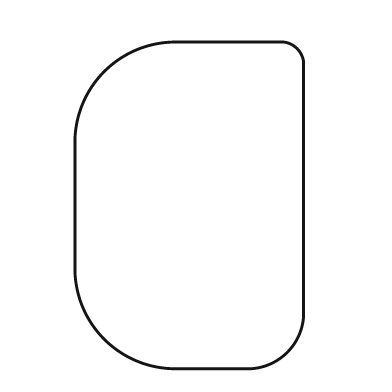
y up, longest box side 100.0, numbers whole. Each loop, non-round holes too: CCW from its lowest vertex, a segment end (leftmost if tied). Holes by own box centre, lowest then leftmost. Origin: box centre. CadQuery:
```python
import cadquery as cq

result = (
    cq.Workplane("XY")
    .moveTo(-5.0, -50.0)
    .lineTo(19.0, -50.0)
    .threePointArc((30.0, -45.0), (35.0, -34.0))
    .lineTo(35.0, 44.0)
    .threePointArc((33.0, 48.0), (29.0, 50.0))
    .lineTo(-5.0, 50.0)
    .threePointArc((-26.0, 41.0), (-35.0, 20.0))
    .lineTo(-35.0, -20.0)
    .threePointArc((-26.0, -41.0), (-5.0, -50.0))
    .close()
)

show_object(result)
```